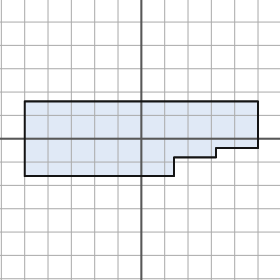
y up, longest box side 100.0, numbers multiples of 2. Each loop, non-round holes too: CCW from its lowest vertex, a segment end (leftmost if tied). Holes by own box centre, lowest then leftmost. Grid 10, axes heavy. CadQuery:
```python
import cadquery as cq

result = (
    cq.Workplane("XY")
    .moveTo(-50.0, -16.0)
    .lineTo(14.0, -16.0)
    .lineTo(14.0, -8.0)
    .lineTo(32.0, -8.0)
    .lineTo(32.0, -4.0)
    .lineTo(50.0, -4.0)
    .lineTo(50.0, 16.0)
    .lineTo(-50.0, 16.0)
    .close()
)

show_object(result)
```